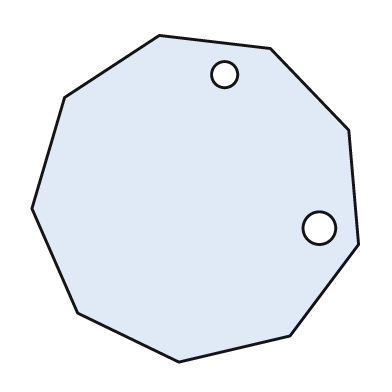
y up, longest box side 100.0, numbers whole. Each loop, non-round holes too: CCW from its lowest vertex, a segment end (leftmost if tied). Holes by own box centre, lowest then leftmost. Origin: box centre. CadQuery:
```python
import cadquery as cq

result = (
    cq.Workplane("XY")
    .moveTo(-5.0, -50.0)
    .lineTo(29.0, -42.0)
    .lineTo(50.0, -14.0)
    .lineTo(47.0, 21.0)
    .lineTo(23.0, 46.0)
    .lineTo(-11.0, 50.0)
    .lineTo(-40.0, 31.0)
    .lineTo(-50.0, -3.0)
    .lineTo(-36.0, -35.0)
    .close()
    .moveTo(38.0, -9.0)
    .circle(5.0)
    .moveTo(9.0, 38.0)
    .circle(4.0)
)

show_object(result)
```